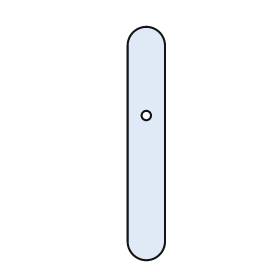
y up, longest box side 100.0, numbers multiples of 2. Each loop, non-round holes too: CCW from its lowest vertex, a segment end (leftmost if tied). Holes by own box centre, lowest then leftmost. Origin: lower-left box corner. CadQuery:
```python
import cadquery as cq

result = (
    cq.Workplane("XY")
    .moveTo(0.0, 8.0)
    .threePointArc((8.0, 0.0), (16.0, 8.0))
    .lineTo(16.0, 92.0)
    .threePointArc((8.0, 100.0), (0.0, 92.0))
    .close()
    .moveTo(8.0, 62.0)
    .circle(2.0)
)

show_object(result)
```